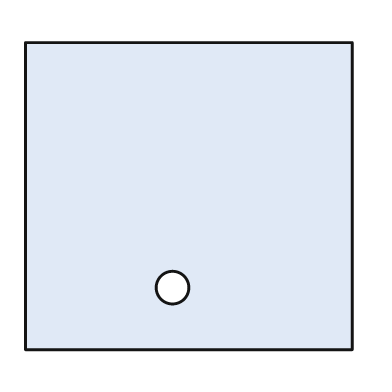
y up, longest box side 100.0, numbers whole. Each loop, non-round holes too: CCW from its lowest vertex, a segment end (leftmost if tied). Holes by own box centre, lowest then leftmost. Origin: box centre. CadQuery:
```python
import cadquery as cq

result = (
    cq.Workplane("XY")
    .moveTo(-50.0, -47.0)
    .lineTo(50.0, -47.0)
    .lineTo(50.0, 47.0)
    .lineTo(-50.0, 47.0)
    .close()
    .moveTo(-5.0, -28.0)
    .circle(5.0)
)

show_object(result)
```